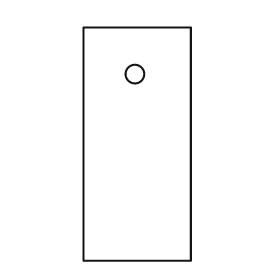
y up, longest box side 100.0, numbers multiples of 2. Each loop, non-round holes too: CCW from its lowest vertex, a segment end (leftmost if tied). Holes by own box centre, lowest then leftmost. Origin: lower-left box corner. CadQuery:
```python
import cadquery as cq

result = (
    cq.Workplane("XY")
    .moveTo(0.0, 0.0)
    .lineTo(46.0, 0.0)
    .lineTo(46.0, 100.0)
    .lineTo(0.0, 100.0)
    .close()
    .moveTo(22.0, 80.0)
    .circle(4.0)
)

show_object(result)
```